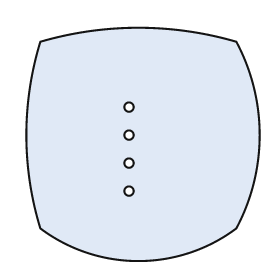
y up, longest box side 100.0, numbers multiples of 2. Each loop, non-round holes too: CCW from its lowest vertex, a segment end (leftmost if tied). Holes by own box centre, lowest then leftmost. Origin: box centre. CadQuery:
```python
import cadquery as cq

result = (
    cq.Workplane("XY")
    .moveTo(-44.0, -36.0)
    .threePointArc((-2.0, -50.0), (40.0, -36.0))
    .threePointArc((50.0, 4.0), (40.0, 44.0))
    .threePointArc((-2.0, 50.0), (-44.0, 44.0))
    .threePointArc((-50.0, 4.0), (-44.0, -36.0))
    .close()
    .moveTo(-6.0, -20.0)
    .circle(2.0)
    .moveTo(-6.0, -8.0)
    .circle(2.0)
    .moveTo(-6.0, 4.0)
    .circle(2.0)
    .moveTo(-6.0, 16.0)
    .circle(2.0)
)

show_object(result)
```